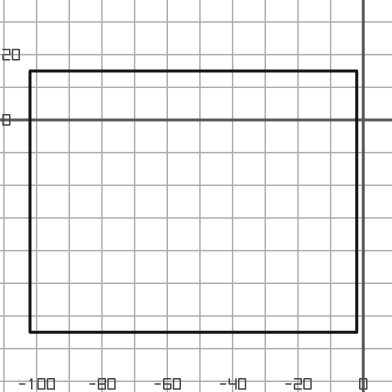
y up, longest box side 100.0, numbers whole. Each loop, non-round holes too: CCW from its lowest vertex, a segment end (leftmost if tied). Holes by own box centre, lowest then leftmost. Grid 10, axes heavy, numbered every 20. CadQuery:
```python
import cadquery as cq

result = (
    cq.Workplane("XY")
    .moveTo(-102.0, -65.0)
    .lineTo(-2.0, -65.0)
    .lineTo(-2.0, 15.0)
    .lineTo(-102.0, 15.0)
    .close()
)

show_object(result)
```